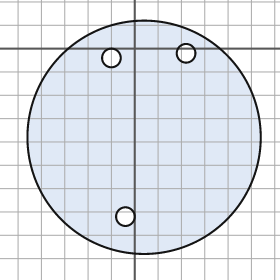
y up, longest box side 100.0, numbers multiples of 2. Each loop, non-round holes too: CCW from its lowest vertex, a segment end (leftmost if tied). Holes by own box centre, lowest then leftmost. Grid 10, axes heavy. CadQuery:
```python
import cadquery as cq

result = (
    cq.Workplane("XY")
    .moveTo(4.0, -38.0)
    .circle(50.0)
    .moveTo(-4.0, -72.0)
    .circle(4.0)
    .moveTo(-10.0, -4.0)
    .circle(4.0)
    .moveTo(22.0, -2.0)
    .circle(4.0)
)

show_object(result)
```